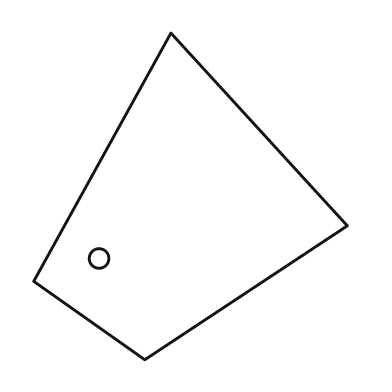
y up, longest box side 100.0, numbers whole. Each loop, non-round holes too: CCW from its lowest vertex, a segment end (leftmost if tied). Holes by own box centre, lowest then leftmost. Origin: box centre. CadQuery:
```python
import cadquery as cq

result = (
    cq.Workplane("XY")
    .moveTo(-14.0, -50.0)
    .lineTo(48.0, -9.0)
    .lineTo(-6.0, 50.0)
    .lineTo(-48.0, -26.0)
    .close()
    .moveTo(-28.0, -19.0)
    .circle(3.0)
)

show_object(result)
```